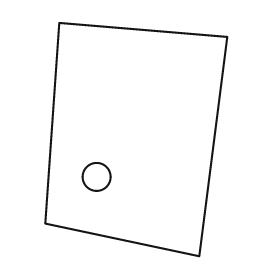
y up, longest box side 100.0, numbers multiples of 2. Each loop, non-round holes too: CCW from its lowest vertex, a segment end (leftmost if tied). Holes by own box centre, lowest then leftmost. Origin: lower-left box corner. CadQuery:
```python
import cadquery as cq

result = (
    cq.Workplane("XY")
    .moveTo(66.0, 0.0)
    .lineTo(78.0, 94.0)
    .lineTo(6.0, 100.0)
    .lineTo(0.0, 14.0)
    .close()
    .moveTo(22.0, 34.0)
    .circle(6.0)
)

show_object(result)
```